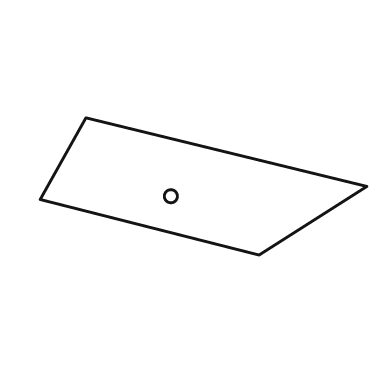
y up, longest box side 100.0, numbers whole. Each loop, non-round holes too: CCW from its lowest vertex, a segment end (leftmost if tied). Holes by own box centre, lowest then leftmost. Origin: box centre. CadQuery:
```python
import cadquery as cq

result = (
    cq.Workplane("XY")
    .moveTo(17.0, -21.0)
    .lineTo(50.0, 0.0)
    .lineTo(-36.0, 21.0)
    .lineTo(-50.0, -4.0)
    .close()
    .moveTo(-10.0, -3.0)
    .circle(2.0)
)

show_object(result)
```